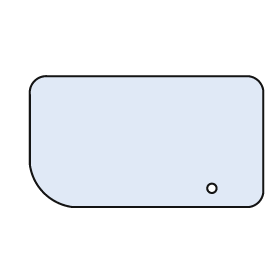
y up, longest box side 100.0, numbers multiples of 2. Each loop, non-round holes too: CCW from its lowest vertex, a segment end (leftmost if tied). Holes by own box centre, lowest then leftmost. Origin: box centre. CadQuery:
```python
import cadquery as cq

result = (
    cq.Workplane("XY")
    .moveTo(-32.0, -28.0)
    .lineTo(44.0, -28.0)
    .threePointArc((48.0, -26.0), (50.0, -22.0))
    .lineTo(50.0, 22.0)
    .threePointArc((48.0, 26.0), (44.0, 28.0))
    .lineTo(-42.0, 28.0)
    .threePointArc((-48.0, 26.0), (-50.0, 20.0))
    .lineTo(-50.0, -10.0)
    .threePointArc((-44.0, -22.0), (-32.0, -28.0))
    .close()
    .moveTo(28.0, -20.0)
    .circle(2.0)
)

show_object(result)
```